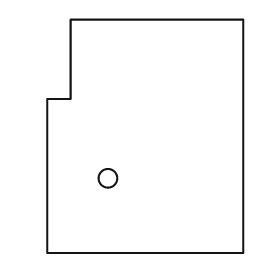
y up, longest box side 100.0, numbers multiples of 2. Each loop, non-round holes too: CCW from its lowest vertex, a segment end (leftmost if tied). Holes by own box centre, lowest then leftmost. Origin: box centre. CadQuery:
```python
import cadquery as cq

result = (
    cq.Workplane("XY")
    .moveTo(-42.0, -50.0)
    .lineTo(42.0, -50.0)
    .lineTo(42.0, 50.0)
    .lineTo(-32.0, 50.0)
    .lineTo(-32.0, 16.0)
    .lineTo(-42.0, 16.0)
    .close()
    .moveTo(-16.0, -18.0)
    .circle(4.0)
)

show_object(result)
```